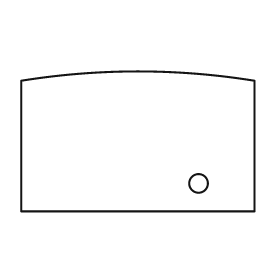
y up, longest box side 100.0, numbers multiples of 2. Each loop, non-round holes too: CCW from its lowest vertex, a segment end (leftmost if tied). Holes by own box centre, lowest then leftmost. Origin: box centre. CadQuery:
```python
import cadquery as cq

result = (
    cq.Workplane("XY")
    .moveTo(-50.0, -30.0)
    .lineTo(50.0, -30.0)
    .lineTo(50.0, 26.0)
    .threePointArc((0.0, 30.0), (-50.0, 26.0))
    .close()
    .moveTo(26.0, -18.0)
    .circle(4.0)
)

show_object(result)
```